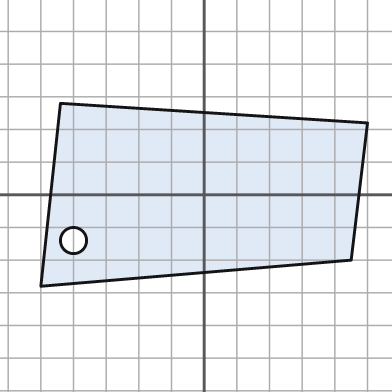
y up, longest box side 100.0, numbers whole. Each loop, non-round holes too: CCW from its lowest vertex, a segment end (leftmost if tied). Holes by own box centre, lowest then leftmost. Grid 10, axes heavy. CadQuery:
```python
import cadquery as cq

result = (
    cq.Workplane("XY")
    .moveTo(-50.0, -28.0)
    .lineTo(45.0, -20.0)
    .lineTo(50.0, 22.0)
    .lineTo(-44.0, 28.0)
    .close()
    .moveTo(-40.0, -14.0)
    .circle(4.0)
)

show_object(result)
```